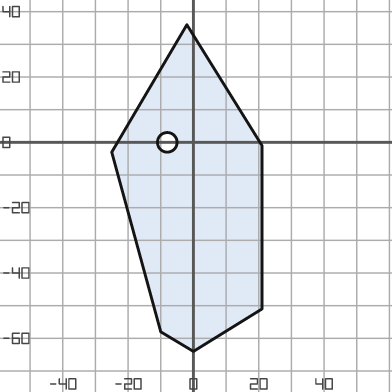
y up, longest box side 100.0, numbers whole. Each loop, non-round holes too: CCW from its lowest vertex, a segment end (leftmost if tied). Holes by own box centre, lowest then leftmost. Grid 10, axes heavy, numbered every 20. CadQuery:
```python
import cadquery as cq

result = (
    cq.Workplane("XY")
    .moveTo(0.0, -64.0)
    .lineTo(21.0, -51.0)
    .lineTo(21.0, -1.0)
    .lineTo(-2.0, 36.0)
    .lineTo(-25.0, -3.0)
    .lineTo(-10.0, -58.0)
    .close()
    .moveTo(-8.0, 0.0)
    .circle(3.0)
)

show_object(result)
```